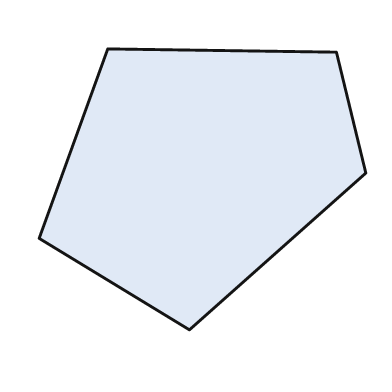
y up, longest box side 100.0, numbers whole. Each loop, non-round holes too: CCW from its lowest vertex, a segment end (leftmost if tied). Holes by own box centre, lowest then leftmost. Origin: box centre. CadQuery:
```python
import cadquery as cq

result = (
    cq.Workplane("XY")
    .moveTo(-4.0, -43.0)
    .lineTo(50.0, 5.0)
    .lineTo(41.0, 42.0)
    .lineTo(-29.0, 43.0)
    .lineTo(-50.0, -15.0)
    .close()
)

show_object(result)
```